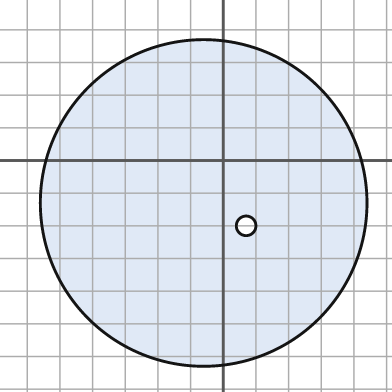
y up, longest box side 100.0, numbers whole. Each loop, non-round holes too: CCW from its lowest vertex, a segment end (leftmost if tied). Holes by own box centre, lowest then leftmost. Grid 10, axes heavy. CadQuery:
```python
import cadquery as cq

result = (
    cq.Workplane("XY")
    .moveTo(-6.0, -13.0)
    .circle(50.0)
    .moveTo(7.0, -20.0)
    .circle(3.0)
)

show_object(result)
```